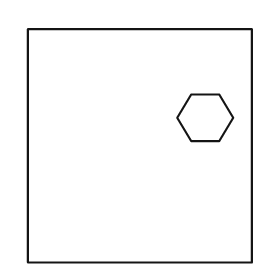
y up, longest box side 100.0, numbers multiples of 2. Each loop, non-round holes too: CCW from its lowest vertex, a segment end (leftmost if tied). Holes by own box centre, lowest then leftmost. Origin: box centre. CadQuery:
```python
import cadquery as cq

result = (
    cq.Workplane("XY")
    .moveTo(-48.0, -50.0)
    .lineTo(48.0, -50.0)
    .lineTo(48.0, 50.0)
    .lineTo(-48.0, 50.0)
    .close()
    .moveTo(22.0, 2.0)
    .lineTo(34.0, 2.0)
    .lineTo(40.0, 12.0)
    .lineTo(34.0, 22.0)
    .lineTo(22.0, 22.0)
    .lineTo(16.0, 12.0)
    .close()
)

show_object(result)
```